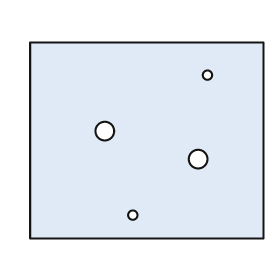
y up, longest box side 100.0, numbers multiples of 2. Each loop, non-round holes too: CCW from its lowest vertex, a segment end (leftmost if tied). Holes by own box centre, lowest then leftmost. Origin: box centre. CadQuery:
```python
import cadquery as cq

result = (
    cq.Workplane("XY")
    .moveTo(-50.0, -42.0)
    .lineTo(50.0, -42.0)
    .lineTo(50.0, 42.0)
    .lineTo(-50.0, 42.0)
    .close()
    .moveTo(-6.0, -32.0)
    .circle(2.0)
    .moveTo(22.0, -8.0)
    .circle(4.0)
    .moveTo(-18.0, 4.0)
    .circle(4.0)
    .moveTo(26.0, 28.0)
    .circle(2.0)
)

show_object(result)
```